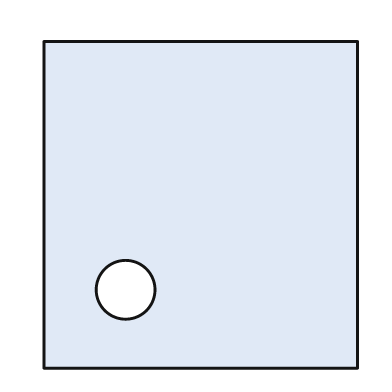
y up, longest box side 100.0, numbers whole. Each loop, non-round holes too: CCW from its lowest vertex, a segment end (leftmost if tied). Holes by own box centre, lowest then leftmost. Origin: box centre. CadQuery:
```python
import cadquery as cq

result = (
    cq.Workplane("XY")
    .moveTo(-48.0, -50.0)
    .lineTo(48.0, -50.0)
    .lineTo(48.0, 50.0)
    .lineTo(-48.0, 50.0)
    .close()
    .moveTo(-23.0, -26.0)
    .circle(9.0)
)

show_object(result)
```